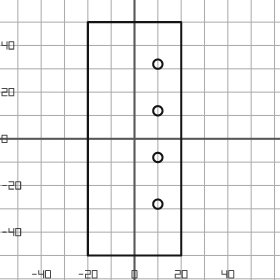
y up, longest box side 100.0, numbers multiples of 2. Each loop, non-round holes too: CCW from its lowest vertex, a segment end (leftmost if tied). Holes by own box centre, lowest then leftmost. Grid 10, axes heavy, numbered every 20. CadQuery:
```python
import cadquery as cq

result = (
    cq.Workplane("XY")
    .moveTo(-20.0, -50.0)
    .lineTo(20.0, -50.0)
    .lineTo(20.0, 50.0)
    .lineTo(-20.0, 50.0)
    .close()
    .moveTo(10.0, -28.0)
    .circle(2.0)
    .moveTo(10.0, -8.0)
    .circle(2.0)
    .moveTo(10.0, 12.0)
    .circle(2.0)
    .moveTo(10.0, 32.0)
    .circle(2.0)
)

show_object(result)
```